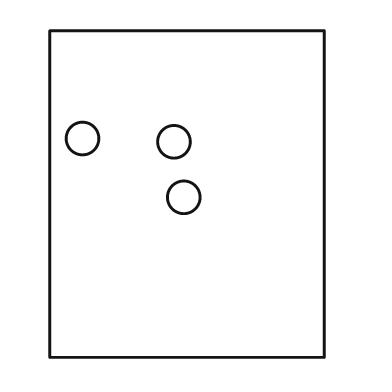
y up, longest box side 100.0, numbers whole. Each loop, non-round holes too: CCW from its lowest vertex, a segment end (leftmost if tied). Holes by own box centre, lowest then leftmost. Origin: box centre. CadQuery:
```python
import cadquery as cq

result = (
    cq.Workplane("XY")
    .moveTo(-42.0, -50.0)
    .lineTo(42.0, -50.0)
    .lineTo(42.0, 50.0)
    .lineTo(-42.0, 50.0)
    .close()
    .moveTo(-1.0, -1.0)
    .circle(5.0)
    .moveTo(-4.0, 16.0)
    .circle(5.0)
    .moveTo(-32.0, 17.0)
    .circle(5.0)
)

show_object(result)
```